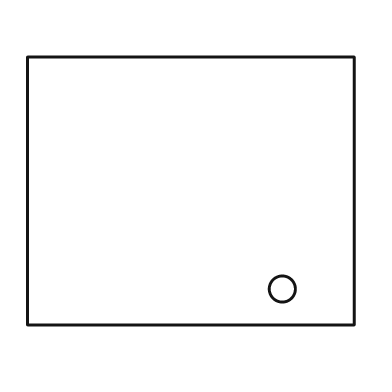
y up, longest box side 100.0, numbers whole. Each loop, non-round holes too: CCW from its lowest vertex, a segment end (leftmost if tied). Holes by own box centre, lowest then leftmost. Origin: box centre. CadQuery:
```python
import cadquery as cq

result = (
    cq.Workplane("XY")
    .moveTo(-50.0, -41.0)
    .lineTo(50.0, -41.0)
    .lineTo(50.0, 41.0)
    .lineTo(-50.0, 41.0)
    .close()
    .moveTo(28.0, -30.0)
    .circle(4.0)
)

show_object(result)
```